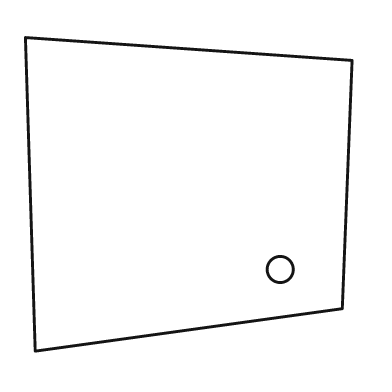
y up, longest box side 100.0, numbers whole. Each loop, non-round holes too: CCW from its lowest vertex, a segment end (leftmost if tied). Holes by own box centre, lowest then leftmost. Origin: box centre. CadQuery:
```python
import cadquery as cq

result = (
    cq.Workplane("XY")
    .moveTo(-47.0, -48.0)
    .lineTo(47.0, -35.0)
    .lineTo(50.0, 41.0)
    .lineTo(-50.0, 48.0)
    .close()
    .moveTo(28.0, -23.0)
    .circle(4.0)
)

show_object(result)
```